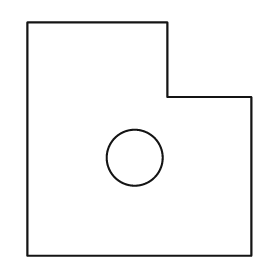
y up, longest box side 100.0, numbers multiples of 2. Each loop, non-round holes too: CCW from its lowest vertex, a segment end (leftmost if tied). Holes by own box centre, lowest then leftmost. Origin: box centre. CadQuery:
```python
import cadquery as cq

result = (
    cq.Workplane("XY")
    .moveTo(-48.0, -50.0)
    .lineTo(48.0, -50.0)
    .lineTo(48.0, 18.0)
    .lineTo(12.0, 18.0)
    .lineTo(12.0, 50.0)
    .lineTo(-48.0, 50.0)
    .close()
    .moveTo(-2.0, -8.0)
    .circle(12.0)
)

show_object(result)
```